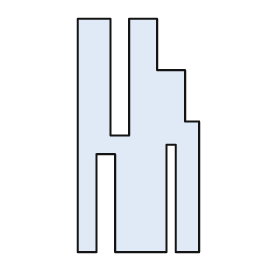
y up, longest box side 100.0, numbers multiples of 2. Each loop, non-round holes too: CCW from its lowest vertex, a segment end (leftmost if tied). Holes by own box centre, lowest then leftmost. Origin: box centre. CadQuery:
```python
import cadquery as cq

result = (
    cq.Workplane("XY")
    .moveTo(-26.0, -50.0)
    .lineTo(-18.0, -50.0)
    .lineTo(-18.0, -8.0)
    .lineTo(-10.0, -8.0)
    .lineTo(-10.0, -50.0)
    .lineTo(12.0, -50.0)
    .lineTo(12.0, -4.0)
    .lineTo(16.0, -4.0)
    .lineTo(16.0, -50.0)
    .lineTo(26.0, -50.0)
    .lineTo(26.0, 6.0)
    .lineTo(20.0, 6.0)
    .lineTo(20.0, 28.0)
    .lineTo(8.0, 28.0)
    .lineTo(8.0, 50.0)
    .lineTo(-4.0, 50.0)
    .lineTo(-4.0, 0.0)
    .lineTo(-12.0, 0.0)
    .lineTo(-12.0, 50.0)
    .lineTo(-26.0, 50.0)
    .close()
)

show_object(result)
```